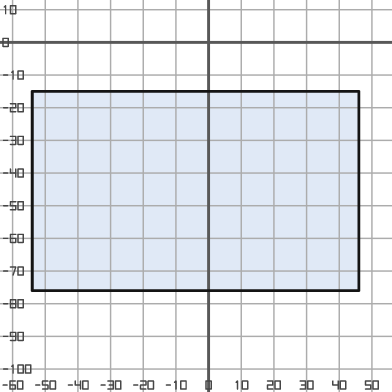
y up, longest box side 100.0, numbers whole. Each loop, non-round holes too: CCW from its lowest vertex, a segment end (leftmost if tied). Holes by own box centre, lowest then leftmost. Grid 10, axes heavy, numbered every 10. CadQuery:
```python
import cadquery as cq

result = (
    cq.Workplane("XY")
    .moveTo(-54.0, -76.0)
    .lineTo(46.0, -76.0)
    .lineTo(46.0, -15.0)
    .lineTo(-54.0, -15.0)
    .close()
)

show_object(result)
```